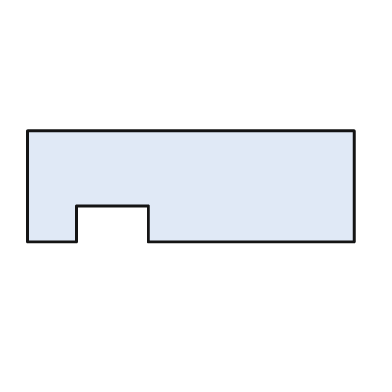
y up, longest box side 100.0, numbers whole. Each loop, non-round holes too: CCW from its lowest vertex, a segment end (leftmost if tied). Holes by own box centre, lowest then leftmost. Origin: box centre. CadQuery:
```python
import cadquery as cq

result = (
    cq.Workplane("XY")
    .moveTo(-50.0, -17.0)
    .lineTo(-35.0, -17.0)
    .lineTo(-35.0, -6.0)
    .lineTo(-13.0, -6.0)
    .lineTo(-13.0, -17.0)
    .lineTo(50.0, -17.0)
    .lineTo(50.0, 17.0)
    .lineTo(-50.0, 17.0)
    .close()
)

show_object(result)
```